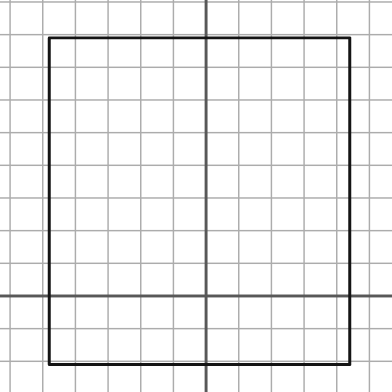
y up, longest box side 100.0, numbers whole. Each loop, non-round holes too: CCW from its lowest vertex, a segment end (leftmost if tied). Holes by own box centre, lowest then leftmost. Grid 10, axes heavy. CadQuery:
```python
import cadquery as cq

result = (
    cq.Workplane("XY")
    .moveTo(-48.0, -21.0)
    .lineTo(44.0, -21.0)
    .lineTo(44.0, 79.0)
    .lineTo(-48.0, 79.0)
    .close()
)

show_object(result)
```